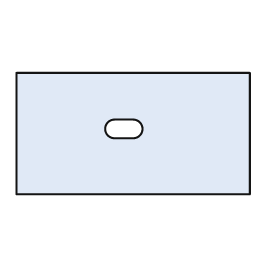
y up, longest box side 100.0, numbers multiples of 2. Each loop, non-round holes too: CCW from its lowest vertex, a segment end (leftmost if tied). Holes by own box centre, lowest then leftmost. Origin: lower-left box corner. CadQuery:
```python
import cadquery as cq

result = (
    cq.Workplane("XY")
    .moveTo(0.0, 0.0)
    .lineTo(100.0, 0.0)
    .lineTo(100.0, 52.0)
    .lineTo(0.0, 52.0)
    .close()
    .moveTo(42.0, 24.0)
    .lineTo(50.0, 24.0)
    .threePointArc((54.0, 28.0), (50.0, 32.0))
    .lineTo(42.0, 32.0)
    .threePointArc((38.0, 28.0), (42.0, 24.0))
    .close()
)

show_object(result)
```